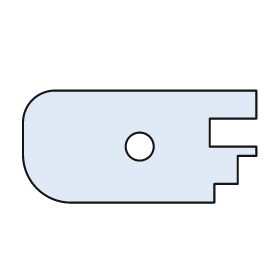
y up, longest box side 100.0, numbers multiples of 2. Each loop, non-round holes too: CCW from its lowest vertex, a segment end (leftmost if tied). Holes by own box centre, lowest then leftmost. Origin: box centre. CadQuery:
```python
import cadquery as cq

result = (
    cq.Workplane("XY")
    .moveTo(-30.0, -24.0)
    .lineTo(32.0, -24.0)
    .lineTo(32.0, -16.0)
    .lineTo(42.0, -16.0)
    .lineTo(42.0, -4.0)
    .lineTo(50.0, -4.0)
    .lineTo(50.0, 0.0)
    .lineTo(30.0, 0.0)
    .lineTo(30.0, 12.0)
    .lineTo(50.0, 12.0)
    .lineTo(50.0, 24.0)
    .lineTo(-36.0, 24.0)
    .threePointArc((-46.0, 20.0), (-50.0, 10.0))
    .lineTo(-50.0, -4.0)
    .threePointArc((-44.0, -18.0), (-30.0, -24.0))
    .close()
    .moveTo(0.0, 0.0)
    .circle(6.0)
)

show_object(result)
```